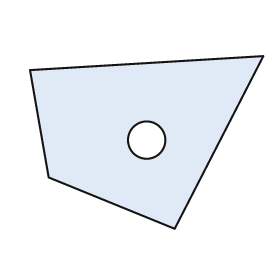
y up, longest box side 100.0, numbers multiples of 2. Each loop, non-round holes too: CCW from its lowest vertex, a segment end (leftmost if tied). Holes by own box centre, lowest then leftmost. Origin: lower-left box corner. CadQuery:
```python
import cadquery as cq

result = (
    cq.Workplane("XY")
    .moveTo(62.0, 0.0)
    .lineTo(100.0, 74.0)
    .lineTo(0.0, 68.0)
    .lineTo(8.0, 22.0)
    .close()
    .moveTo(50.0, 38.0)
    .circle(8.0)
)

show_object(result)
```